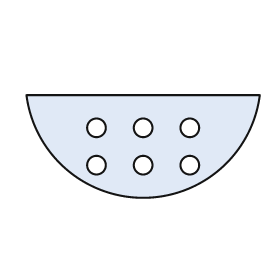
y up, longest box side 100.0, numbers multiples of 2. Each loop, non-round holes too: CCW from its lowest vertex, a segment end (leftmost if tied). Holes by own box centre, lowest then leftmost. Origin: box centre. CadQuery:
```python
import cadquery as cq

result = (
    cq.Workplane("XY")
    .moveTo(-50.0, 22.0)
    .threePointArc((0.0, -22.0), (50.0, 22.0))
    .close()
    .moveTo(-20.0, -8.0)
    .circle(4.0)
    .moveTo(0.0, -8.0)
    .circle(4.0)
    .moveTo(20.0, -8.0)
    .circle(4.0)
    .moveTo(-20.0, 8.0)
    .circle(4.0)
    .moveTo(0.0, 8.0)
    .circle(4.0)
    .moveTo(20.0, 8.0)
    .circle(4.0)
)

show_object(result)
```